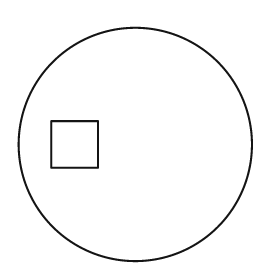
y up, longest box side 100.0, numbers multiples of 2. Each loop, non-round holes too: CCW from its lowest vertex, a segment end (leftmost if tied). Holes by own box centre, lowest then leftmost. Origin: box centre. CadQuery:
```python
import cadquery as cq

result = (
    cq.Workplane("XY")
    .moveTo(0.0, 0.0)
    .circle(50.0)
    .moveTo(-36.0, -10.0)
    .lineTo(-16.0, -10.0)
    .lineTo(-16.0, 10.0)
    .lineTo(-36.0, 10.0)
    .close()
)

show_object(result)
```